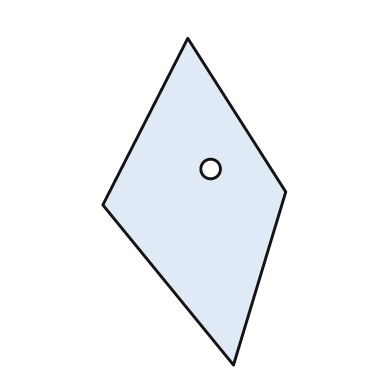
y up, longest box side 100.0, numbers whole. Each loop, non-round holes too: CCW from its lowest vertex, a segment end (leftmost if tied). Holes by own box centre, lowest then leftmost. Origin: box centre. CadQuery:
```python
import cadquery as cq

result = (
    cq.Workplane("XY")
    .moveTo(12.0, -50.0)
    .lineTo(28.0, 3.0)
    .lineTo(-2.0, 50.0)
    .lineTo(-28.0, -1.0)
    .close()
    .moveTo(5.0, 10.0)
    .circle(3.0)
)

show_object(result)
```